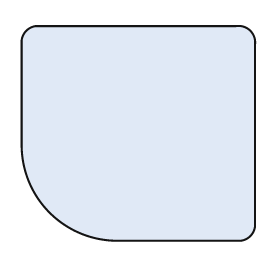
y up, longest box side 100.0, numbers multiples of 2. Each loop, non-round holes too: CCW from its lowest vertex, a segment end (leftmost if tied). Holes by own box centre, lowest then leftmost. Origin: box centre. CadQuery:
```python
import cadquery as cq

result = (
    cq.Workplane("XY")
    .moveTo(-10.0, -46.0)
    .lineTo(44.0, -46.0)
    .threePointArc((48.0, -44.0), (50.0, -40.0))
    .lineTo(50.0, 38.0)
    .threePointArc((48.0, 44.0), (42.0, 46.0))
    .lineTo(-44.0, 46.0)
    .threePointArc((-48.0, 44.0), (-50.0, 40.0))
    .lineTo(-50.0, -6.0)
    .threePointArc((-38.0, -34.0), (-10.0, -46.0))
    .close()
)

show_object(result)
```